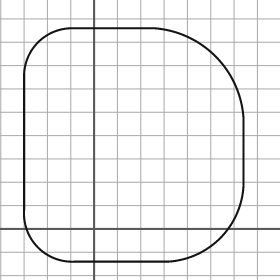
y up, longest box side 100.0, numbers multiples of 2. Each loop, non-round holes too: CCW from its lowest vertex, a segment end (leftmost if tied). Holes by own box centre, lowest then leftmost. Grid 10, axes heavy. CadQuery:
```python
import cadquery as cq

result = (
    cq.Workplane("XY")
    .moveTo(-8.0, -14.0)
    .lineTo(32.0, -14.0)
    .threePointArc((54.0, -4.0), (64.0, 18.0))
    .lineTo(64.0, 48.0)
    .threePointArc((52.0, 74.0), (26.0, 86.0))
    .lineTo(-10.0, 86.0)
    .threePointArc((-24.0, 80.0), (-30.0, 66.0))
    .lineTo(-30.0, 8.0)
    .threePointArc((-24.0, -8.0), (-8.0, -14.0))
    .close()
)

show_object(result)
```